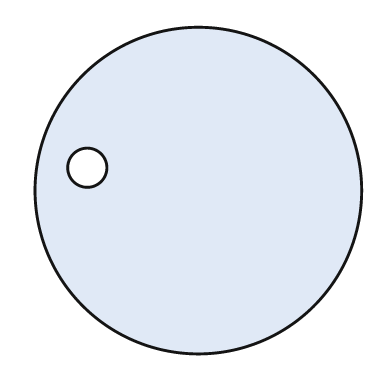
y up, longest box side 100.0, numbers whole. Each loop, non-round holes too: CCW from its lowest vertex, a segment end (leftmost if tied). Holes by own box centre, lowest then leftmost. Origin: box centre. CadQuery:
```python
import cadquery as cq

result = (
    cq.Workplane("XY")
    .moveTo(0.0, 0.0)
    .circle(50.0)
    .moveTo(-34.0, 7.0)
    .circle(6.0)
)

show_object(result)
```